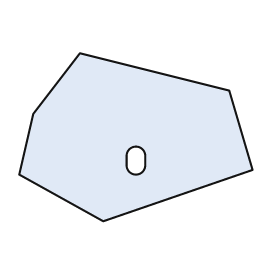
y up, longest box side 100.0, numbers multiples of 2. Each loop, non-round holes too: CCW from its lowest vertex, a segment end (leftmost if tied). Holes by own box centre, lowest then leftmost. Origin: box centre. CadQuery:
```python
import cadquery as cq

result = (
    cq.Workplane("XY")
    .moveTo(-14.0, -36.0)
    .lineTo(50.0, -14.0)
    .lineTo(40.0, 20.0)
    .lineTo(-24.0, 36.0)
    .lineTo(-44.0, 10.0)
    .lineTo(-50.0, -16.0)
    .close()
    .moveTo(-4.0, -12.0)
    .threePointArc((0.0, -16.0), (4.0, -12.0))
    .lineTo(4.0, -8.0)
    .threePointArc((0.0, -4.0), (-4.0, -8.0))
    .close()
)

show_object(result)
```